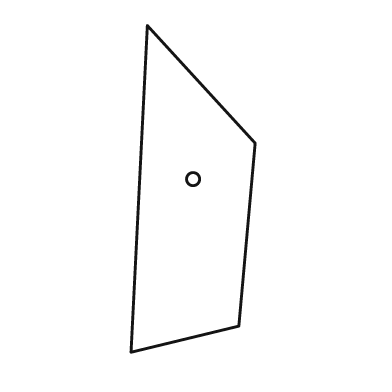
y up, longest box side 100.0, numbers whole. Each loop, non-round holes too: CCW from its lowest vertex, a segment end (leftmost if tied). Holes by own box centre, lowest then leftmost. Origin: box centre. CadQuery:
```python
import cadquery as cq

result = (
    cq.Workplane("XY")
    .moveTo(-19.0, -50.0)
    .lineTo(14.0, -42.0)
    .lineTo(19.0, 14.0)
    .lineTo(-14.0, 50.0)
    .close()
    .moveTo(0.0, 3.0)
    .circle(2.0)
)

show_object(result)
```